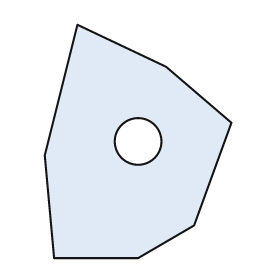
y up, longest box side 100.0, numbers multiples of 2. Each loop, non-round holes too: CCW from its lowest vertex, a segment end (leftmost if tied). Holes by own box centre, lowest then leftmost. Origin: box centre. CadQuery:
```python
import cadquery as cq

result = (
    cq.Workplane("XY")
    .moveTo(-36.0, -50.0)
    .lineTo(0.0, -50.0)
    .lineTo(24.0, -36.0)
    .lineTo(40.0, 8.0)
    .lineTo(12.0, 32.0)
    .lineTo(-26.0, 50.0)
    .lineTo(-40.0, -6.0)
    .close()
    .moveTo(0.0, 0.0)
    .circle(10.0)
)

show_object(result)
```